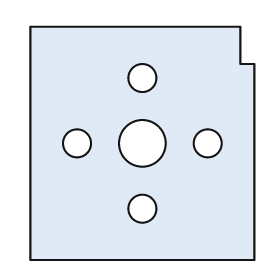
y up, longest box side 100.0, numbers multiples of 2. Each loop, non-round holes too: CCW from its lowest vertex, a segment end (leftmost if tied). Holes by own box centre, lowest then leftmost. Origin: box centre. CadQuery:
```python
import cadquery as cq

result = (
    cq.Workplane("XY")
    .moveTo(-48.0, -50.0)
    .lineTo(48.0, -50.0)
    .lineTo(48.0, 34.0)
    .lineTo(42.0, 34.0)
    .lineTo(42.0, 50.0)
    .lineTo(-48.0, 50.0)
    .close()
    .moveTo(0.0, -28.0)
    .circle(6.0)
    .moveTo(-28.0, 0.0)
    .circle(6.0)
    .moveTo(0.0, 0.0)
    .circle(10.0)
    .moveTo(28.0, 0.0)
    .circle(6.0)
    .moveTo(0.0, 28.0)
    .circle(6.0)
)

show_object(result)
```